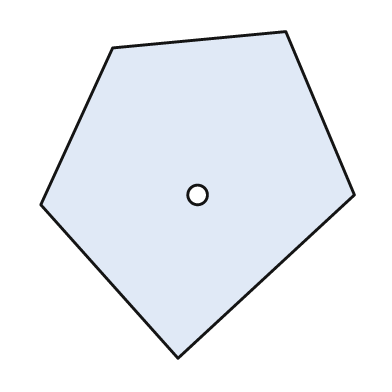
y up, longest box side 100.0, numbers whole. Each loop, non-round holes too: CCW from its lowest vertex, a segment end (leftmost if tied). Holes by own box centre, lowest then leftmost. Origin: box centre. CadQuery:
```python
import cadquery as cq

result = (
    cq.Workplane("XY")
    .moveTo(-6.0, -50.0)
    .lineTo(48.0, 0.0)
    .lineTo(27.0, 50.0)
    .lineTo(-26.0, 45.0)
    .lineTo(-48.0, -3.0)
    .close()
    .moveTo(0.0, 0.0)
    .circle(3.0)
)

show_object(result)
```